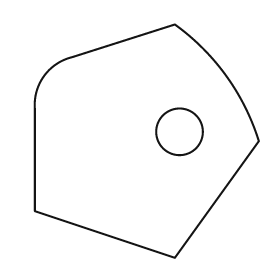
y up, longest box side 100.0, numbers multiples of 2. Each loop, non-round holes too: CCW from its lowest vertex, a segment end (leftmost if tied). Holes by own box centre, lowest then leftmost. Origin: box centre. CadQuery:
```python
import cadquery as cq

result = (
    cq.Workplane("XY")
    .moveTo(12.0, -50.0)
    .lineTo(48.0, 0.0)
    .threePointArc((34.0, 28.0), (12.0, 50.0))
    .lineTo(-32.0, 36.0)
    .threePointArc((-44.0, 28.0), (-48.0, 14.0))
    .lineTo(-48.0, -30.0)
    .close()
    .moveTo(14.0, 4.0)
    .circle(10.0)
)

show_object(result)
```